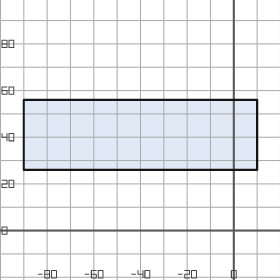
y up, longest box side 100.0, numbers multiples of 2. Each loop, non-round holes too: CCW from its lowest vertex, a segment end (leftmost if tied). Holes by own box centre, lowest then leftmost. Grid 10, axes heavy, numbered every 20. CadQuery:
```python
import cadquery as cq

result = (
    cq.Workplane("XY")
    .moveTo(-90.0, 26.0)
    .lineTo(10.0, 26.0)
    .lineTo(10.0, 56.0)
    .lineTo(-90.0, 56.0)
    .close()
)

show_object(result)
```